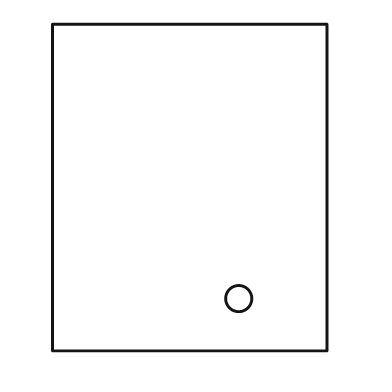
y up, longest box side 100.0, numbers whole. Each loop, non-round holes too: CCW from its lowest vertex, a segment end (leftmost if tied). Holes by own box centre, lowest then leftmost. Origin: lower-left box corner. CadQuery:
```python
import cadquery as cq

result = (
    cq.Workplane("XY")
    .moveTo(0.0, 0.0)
    .lineTo(84.0, 0.0)
    .lineTo(84.0, 100.0)
    .lineTo(0.0, 100.0)
    .close()
    .moveTo(57.0, 16.0)
    .circle(4.0)
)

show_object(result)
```